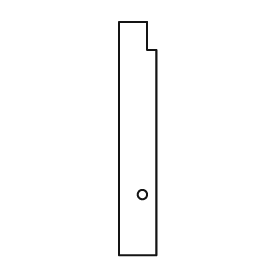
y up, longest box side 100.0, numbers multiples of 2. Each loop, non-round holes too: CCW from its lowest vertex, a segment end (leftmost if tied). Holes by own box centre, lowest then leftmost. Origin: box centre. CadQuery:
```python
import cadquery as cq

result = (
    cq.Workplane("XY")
    .moveTo(-8.0, -50.0)
    .lineTo(8.0, -50.0)
    .lineTo(8.0, 38.0)
    .lineTo(4.0, 38.0)
    .lineTo(4.0, 50.0)
    .lineTo(-8.0, 50.0)
    .close()
    .moveTo(2.0, -24.0)
    .circle(2.0)
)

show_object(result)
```